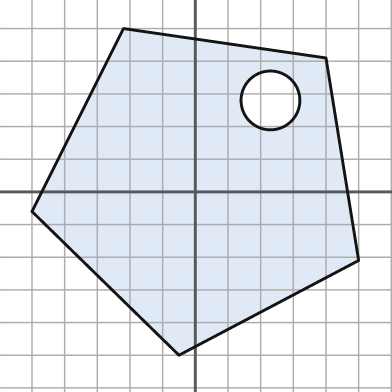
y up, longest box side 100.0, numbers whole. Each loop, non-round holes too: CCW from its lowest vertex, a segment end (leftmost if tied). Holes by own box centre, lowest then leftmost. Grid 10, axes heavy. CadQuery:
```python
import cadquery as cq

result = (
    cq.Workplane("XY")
    .moveTo(-5.0, -50.0)
    .lineTo(50.0, -21.0)
    .lineTo(40.0, 41.0)
    .lineTo(-22.0, 50.0)
    .lineTo(-50.0, -6.0)
    .close()
    .moveTo(23.0, 28.0)
    .circle(9.0)
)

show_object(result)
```